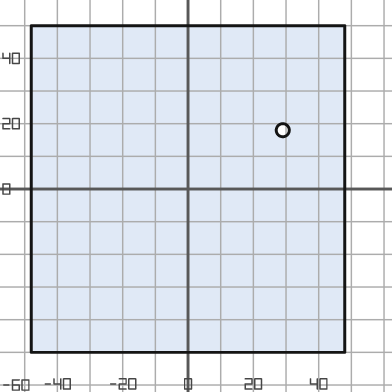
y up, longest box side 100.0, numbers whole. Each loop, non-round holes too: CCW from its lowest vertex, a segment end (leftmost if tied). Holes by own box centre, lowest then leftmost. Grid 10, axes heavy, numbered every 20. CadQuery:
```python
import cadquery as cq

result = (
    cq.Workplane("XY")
    .moveTo(-48.0, -50.0)
    .lineTo(48.0, -50.0)
    .lineTo(48.0, 50.0)
    .lineTo(-48.0, 50.0)
    .close()
    .moveTo(29.0, 18.0)
    .circle(2.0)
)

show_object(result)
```